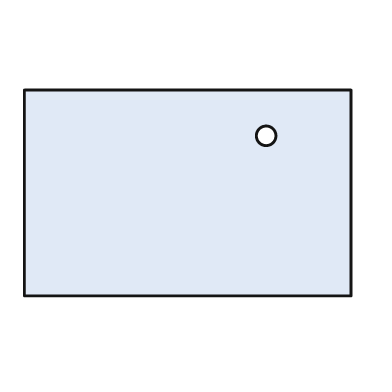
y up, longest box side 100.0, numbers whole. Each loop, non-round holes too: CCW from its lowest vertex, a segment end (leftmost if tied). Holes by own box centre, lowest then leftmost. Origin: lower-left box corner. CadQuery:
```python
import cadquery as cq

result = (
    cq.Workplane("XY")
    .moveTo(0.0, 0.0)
    .lineTo(100.0, 0.0)
    .lineTo(100.0, 63.0)
    .lineTo(0.0, 63.0)
    .close()
    .moveTo(74.0, 49.0)
    .circle(3.0)
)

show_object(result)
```